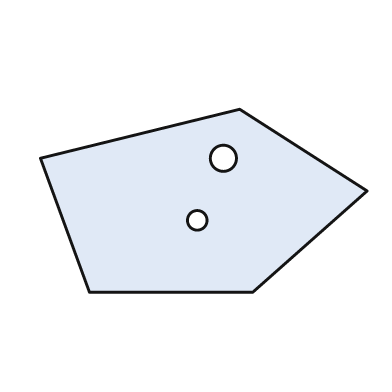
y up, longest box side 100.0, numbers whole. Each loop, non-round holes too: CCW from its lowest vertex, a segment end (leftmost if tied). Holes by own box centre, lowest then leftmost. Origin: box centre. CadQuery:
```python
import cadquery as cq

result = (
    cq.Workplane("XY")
    .moveTo(-35.0, -28.0)
    .lineTo(15.0, -28.0)
    .lineTo(50.0, 3.0)
    .lineTo(11.0, 28.0)
    .lineTo(-50.0, 13.0)
    .close()
    .moveTo(-2.0, -6.0)
    .circle(3.0)
    .moveTo(6.0, 13.0)
    .circle(4.0)
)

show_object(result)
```